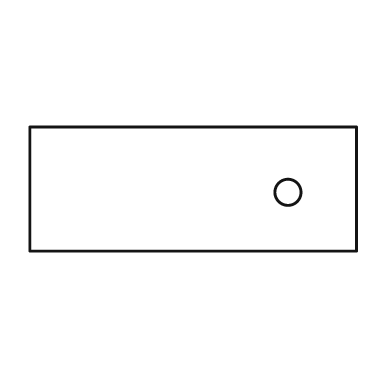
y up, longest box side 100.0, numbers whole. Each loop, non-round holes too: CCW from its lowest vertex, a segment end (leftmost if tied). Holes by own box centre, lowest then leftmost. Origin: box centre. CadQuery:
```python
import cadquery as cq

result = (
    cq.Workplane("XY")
    .moveTo(-50.0, -19.0)
    .lineTo(50.0, -19.0)
    .lineTo(50.0, 19.0)
    .lineTo(-50.0, 19.0)
    .close()
    .moveTo(29.0, -1.0)
    .circle(4.0)
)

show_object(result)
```